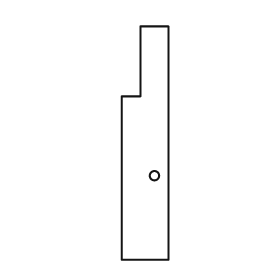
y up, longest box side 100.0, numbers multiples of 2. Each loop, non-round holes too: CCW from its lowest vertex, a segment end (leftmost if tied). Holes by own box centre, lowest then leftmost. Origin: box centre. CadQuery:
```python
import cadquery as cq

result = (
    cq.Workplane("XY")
    .moveTo(-10.0, -50.0)
    .lineTo(10.0, -50.0)
    .lineTo(10.0, 50.0)
    .lineTo(-2.0, 50.0)
    .lineTo(-2.0, 20.0)
    .lineTo(-10.0, 20.0)
    .close()
    .moveTo(4.0, -14.0)
    .circle(2.0)
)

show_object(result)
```